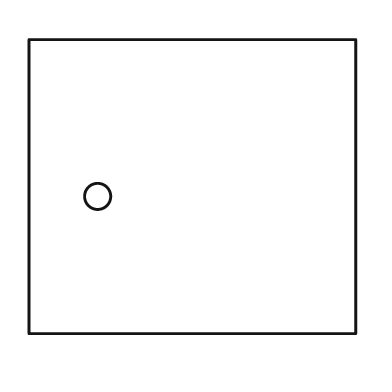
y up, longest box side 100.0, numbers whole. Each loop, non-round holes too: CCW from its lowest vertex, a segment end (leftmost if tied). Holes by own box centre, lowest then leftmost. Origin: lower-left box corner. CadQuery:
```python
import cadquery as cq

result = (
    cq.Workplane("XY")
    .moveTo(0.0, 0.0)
    .lineTo(100.0, 0.0)
    .lineTo(100.0, 90.0)
    .lineTo(0.0, 90.0)
    .close()
    .moveTo(21.0, 42.0)
    .circle(4.0)
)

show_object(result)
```